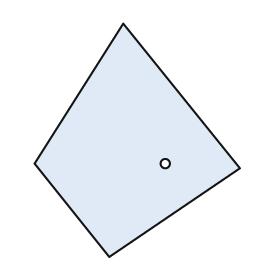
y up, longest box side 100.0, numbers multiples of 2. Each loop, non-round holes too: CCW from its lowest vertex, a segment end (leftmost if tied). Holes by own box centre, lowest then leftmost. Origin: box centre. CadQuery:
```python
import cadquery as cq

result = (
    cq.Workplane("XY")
    .moveTo(-12.0, -50.0)
    .lineTo(44.0, -12.0)
    .lineTo(-6.0, 50.0)
    .lineTo(-44.0, -10.0)
    .close()
    .moveTo(12.0, -10.0)
    .circle(2.0)
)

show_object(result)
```